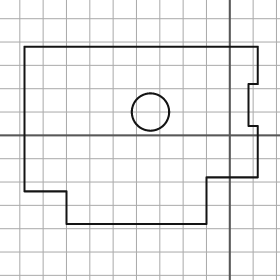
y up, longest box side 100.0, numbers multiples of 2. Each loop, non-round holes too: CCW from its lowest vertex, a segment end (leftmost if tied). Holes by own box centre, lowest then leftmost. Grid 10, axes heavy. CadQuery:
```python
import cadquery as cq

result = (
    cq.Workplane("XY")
    .moveTo(-70.0, -38.0)
    .lineTo(-10.0, -38.0)
    .lineTo(-10.0, -18.0)
    .lineTo(12.0, -18.0)
    .lineTo(12.0, 4.0)
    .lineTo(8.0, 4.0)
    .lineTo(8.0, 22.0)
    .lineTo(12.0, 22.0)
    .lineTo(12.0, 38.0)
    .lineTo(-88.0, 38.0)
    .lineTo(-88.0, -24.0)
    .lineTo(-70.0, -24.0)
    .close()
    .moveTo(-34.0, 10.0)
    .circle(8.0)
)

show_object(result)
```